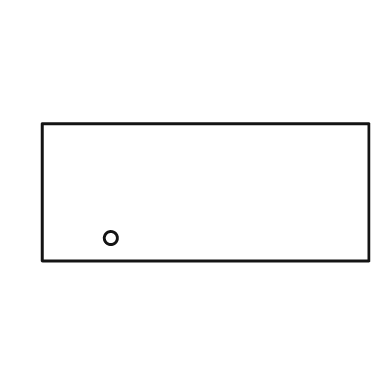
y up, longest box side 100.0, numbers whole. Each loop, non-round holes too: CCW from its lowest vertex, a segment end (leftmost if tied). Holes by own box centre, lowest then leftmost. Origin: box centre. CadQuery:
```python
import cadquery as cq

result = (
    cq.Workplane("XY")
    .moveTo(-50.0, -21.0)
    .lineTo(50.0, -21.0)
    .lineTo(50.0, 21.0)
    .lineTo(-50.0, 21.0)
    .close()
    .moveTo(-29.0, -14.0)
    .circle(2.0)
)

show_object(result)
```